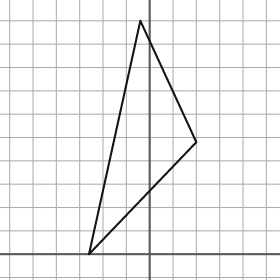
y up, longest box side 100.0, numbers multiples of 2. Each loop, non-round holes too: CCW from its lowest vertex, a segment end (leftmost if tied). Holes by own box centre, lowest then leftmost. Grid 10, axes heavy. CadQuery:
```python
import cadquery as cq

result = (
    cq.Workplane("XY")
    .moveTo(-26.0, 0.0)
    .lineTo(20.0, 48.0)
    .lineTo(-4.0, 100.0)
    .close()
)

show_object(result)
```